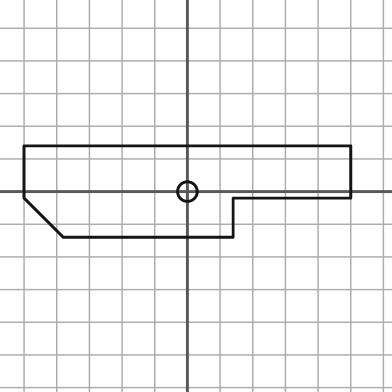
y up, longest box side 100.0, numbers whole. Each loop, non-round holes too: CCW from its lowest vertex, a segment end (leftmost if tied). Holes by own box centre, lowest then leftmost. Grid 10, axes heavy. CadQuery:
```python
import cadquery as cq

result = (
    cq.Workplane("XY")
    .moveTo(-38.0, -14.0)
    .lineTo(14.0, -14.0)
    .lineTo(14.0, -2.0)
    .lineTo(50.0, -2.0)
    .lineTo(50.0, 14.0)
    .lineTo(-50.0, 14.0)
    .lineTo(-50.0, -2.0)
    .close()
    .moveTo(0.0, 0.0)
    .circle(3.0)
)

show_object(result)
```